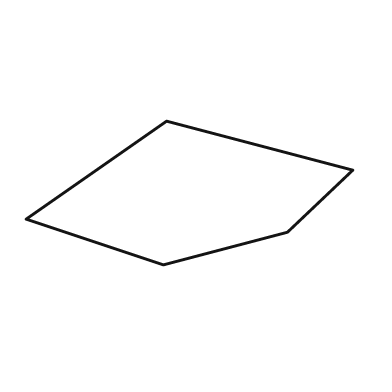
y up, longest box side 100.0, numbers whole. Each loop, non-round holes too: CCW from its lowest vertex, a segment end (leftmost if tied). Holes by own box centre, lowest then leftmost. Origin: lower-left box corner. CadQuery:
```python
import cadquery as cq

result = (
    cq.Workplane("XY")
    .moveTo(42.0, 0.0)
    .lineTo(80.0, 10.0)
    .lineTo(100.0, 29.0)
    .lineTo(43.0, 44.0)
    .lineTo(0.0, 14.0)
    .close()
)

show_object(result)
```